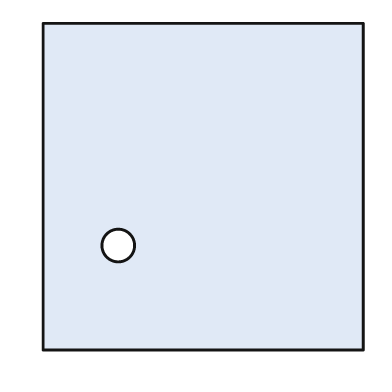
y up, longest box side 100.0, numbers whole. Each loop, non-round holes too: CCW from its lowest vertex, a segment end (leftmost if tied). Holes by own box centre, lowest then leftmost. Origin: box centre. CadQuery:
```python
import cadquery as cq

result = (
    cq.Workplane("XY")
    .moveTo(-49.0, -50.0)
    .lineTo(49.0, -50.0)
    .lineTo(49.0, 50.0)
    .lineTo(-49.0, 50.0)
    .close()
    .moveTo(-26.0, -18.0)
    .circle(5.0)
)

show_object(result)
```